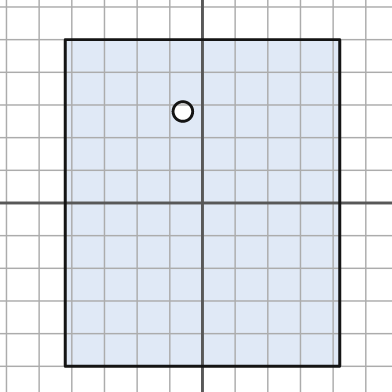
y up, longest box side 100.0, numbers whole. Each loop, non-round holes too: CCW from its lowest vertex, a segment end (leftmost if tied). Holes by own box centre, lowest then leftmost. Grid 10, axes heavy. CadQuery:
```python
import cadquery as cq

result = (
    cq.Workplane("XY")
    .moveTo(-42.0, -50.0)
    .lineTo(42.0, -50.0)
    .lineTo(42.0, 50.0)
    .lineTo(-42.0, 50.0)
    .close()
    .moveTo(-6.0, 28.0)
    .circle(3.0)
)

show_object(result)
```